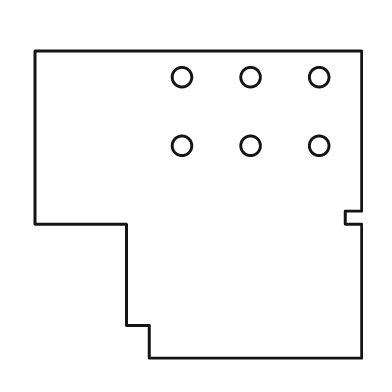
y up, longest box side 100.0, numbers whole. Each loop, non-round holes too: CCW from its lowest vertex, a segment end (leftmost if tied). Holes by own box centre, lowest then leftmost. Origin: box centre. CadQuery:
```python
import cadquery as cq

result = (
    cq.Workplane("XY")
    .moveTo(-15.0, -47.0)
    .lineTo(50.0, -47.0)
    .lineTo(50.0, -6.0)
    .lineTo(45.0, -6.0)
    .lineTo(45.0, -2.0)
    .lineTo(50.0, -2.0)
    .lineTo(50.0, 47.0)
    .lineTo(-50.0, 47.0)
    .lineTo(-50.0, -6.0)
    .lineTo(-22.0, -6.0)
    .lineTo(-22.0, -37.0)
    .lineTo(-15.0, -37.0)
    .close()
    .moveTo(-5.0, 18.0)
    .circle(3.0)
    .moveTo(16.0, 18.0)
    .circle(3.0)
    .moveTo(37.0, 18.0)
    .circle(3.0)
    .moveTo(-5.0, 39.0)
    .circle(3.0)
    .moveTo(16.0, 39.0)
    .circle(3.0)
    .moveTo(37.0, 39.0)
    .circle(3.0)
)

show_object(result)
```